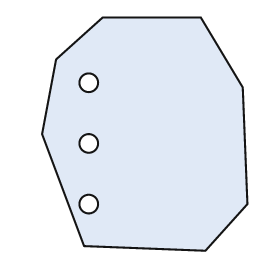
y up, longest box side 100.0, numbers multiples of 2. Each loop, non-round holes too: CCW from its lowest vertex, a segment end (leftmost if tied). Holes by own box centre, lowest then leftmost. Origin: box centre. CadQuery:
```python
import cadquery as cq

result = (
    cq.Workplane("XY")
    .moveTo(26.0, -50.0)
    .lineTo(44.0, -30.0)
    .lineTo(42.0, 20.0)
    .lineTo(24.0, 50.0)
    .lineTo(-18.0, 50.0)
    .lineTo(-38.0, 32.0)
    .lineTo(-44.0, 0.0)
    .lineTo(-26.0, -48.0)
    .close()
    .moveTo(-24.0, -30.0)
    .circle(4.0)
    .moveTo(-24.0, -4.0)
    .circle(4.0)
    .moveTo(-24.0, 22.0)
    .circle(4.0)
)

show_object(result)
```